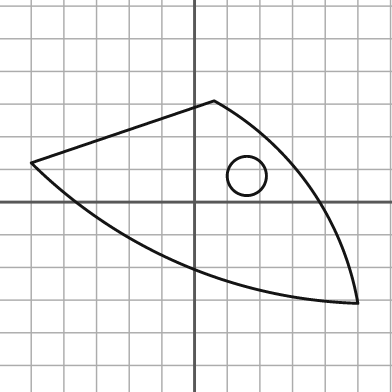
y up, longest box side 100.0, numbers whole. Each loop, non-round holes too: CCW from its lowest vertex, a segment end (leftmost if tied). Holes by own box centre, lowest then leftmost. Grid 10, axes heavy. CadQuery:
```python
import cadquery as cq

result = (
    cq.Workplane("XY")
    .moveTo(50.0, -31.0)
    .threePointArc((35.0, 5.0), (6.0, 31.0))
    .lineTo(-50.0, 12.0)
    .threePointArc((-4.0, -19.0), (50.0, -31.0))
    .close()
    .moveTo(16.0, 8.0)
    .circle(6.0)
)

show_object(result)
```